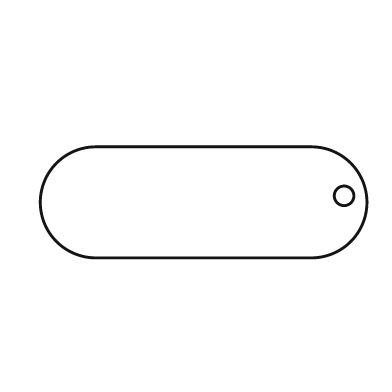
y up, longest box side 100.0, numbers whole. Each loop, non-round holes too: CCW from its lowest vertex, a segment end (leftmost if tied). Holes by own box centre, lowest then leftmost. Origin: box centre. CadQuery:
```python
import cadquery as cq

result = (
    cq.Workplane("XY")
    .moveTo(-33.0, -17.0)
    .lineTo(33.0, -17.0)
    .threePointArc((50.0, 0.0), (33.0, 17.0))
    .lineTo(-33.0, 17.0)
    .threePointArc((-50.0, 0.0), (-33.0, -17.0))
    .close()
    .moveTo(43.0, 2.0)
    .circle(3.0)
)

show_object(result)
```